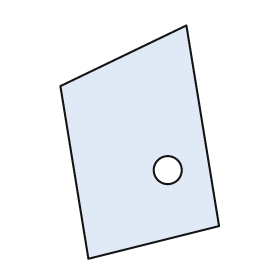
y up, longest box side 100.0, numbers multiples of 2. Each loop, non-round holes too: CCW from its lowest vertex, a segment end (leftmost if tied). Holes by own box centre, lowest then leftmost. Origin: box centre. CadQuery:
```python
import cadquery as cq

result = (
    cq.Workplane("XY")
    .moveTo(-22.0, -50.0)
    .lineTo(34.0, -36.0)
    .lineTo(20.0, 50.0)
    .lineTo(-34.0, 24.0)
    .close()
    .moveTo(12.0, -12.0)
    .circle(6.0)
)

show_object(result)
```